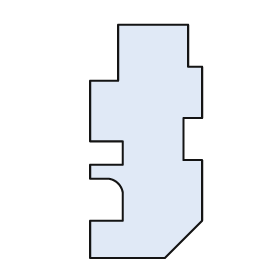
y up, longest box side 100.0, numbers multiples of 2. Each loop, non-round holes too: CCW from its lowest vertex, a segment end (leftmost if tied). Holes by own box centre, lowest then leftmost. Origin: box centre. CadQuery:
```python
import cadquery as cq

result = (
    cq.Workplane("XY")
    .moveTo(-24.0, -50.0)
    .lineTo(8.0, -50.0)
    .lineTo(24.0, -34.0)
    .lineTo(24.0, -8.0)
    .lineTo(16.0, -8.0)
    .lineTo(16.0, 10.0)
    .lineTo(24.0, 10.0)
    .lineTo(24.0, 32.0)
    .lineTo(18.0, 32.0)
    .lineTo(18.0, 50.0)
    .lineTo(-12.0, 50.0)
    .lineTo(-12.0, 26.0)
    .lineTo(-24.0, 26.0)
    .lineTo(-24.0, 0.0)
    .lineTo(-10.0, 0.0)
    .lineTo(-10.0, -10.0)
    .lineTo(-24.0, -10.0)
    .lineTo(-24.0, -16.0)
    .lineTo(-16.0, -16.0)
    .threePointArc((-12.0, -18.0), (-10.0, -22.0))
    .lineTo(-10.0, -34.0)
    .lineTo(-24.0, -34.0)
    .close()
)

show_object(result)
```